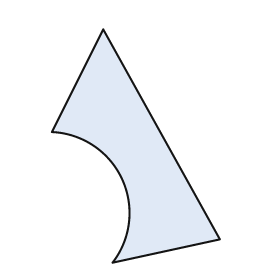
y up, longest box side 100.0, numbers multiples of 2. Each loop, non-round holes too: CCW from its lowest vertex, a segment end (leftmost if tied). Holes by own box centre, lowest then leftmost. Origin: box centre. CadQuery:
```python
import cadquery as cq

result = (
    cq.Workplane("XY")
    .moveTo(-10.0, -50.0)
    .lineTo(36.0, -40.0)
    .lineTo(-14.0, 50.0)
    .lineTo(-36.0, 6.0)
    .threePointArc((-6.0, -14.0), (-10.0, -50.0))
    .close()
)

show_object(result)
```